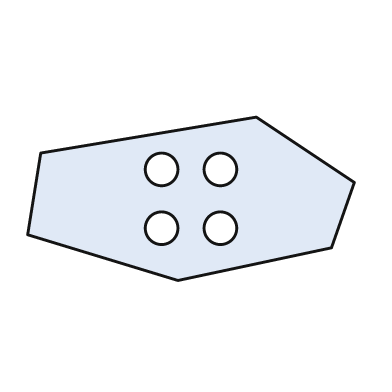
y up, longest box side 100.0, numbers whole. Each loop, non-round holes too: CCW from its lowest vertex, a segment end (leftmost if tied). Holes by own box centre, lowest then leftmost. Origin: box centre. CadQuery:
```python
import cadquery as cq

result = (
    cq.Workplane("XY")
    .moveTo(-4.0, -25.0)
    .lineTo(43.0, -15.0)
    .lineTo(50.0, 5.0)
    .lineTo(20.0, 25.0)
    .lineTo(-46.0, 14.0)
    .lineTo(-50.0, -11.0)
    .close()
    .moveTo(-9.0, -9.0)
    .circle(5.0)
    .moveTo(9.0, -9.0)
    .circle(5.0)
    .moveTo(-9.0, 9.0)
    .circle(5.0)
    .moveTo(9.0, 9.0)
    .circle(5.0)
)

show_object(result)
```